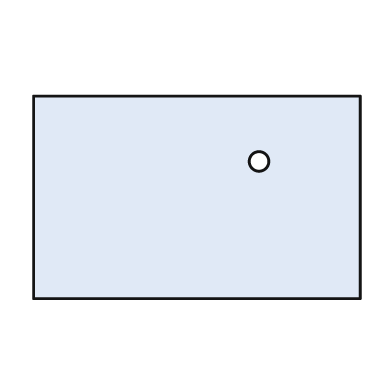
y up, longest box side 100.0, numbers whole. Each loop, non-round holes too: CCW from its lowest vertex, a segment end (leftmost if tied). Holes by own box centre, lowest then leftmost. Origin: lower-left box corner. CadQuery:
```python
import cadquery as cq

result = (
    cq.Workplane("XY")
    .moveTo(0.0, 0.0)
    .lineTo(100.0, 0.0)
    .lineTo(100.0, 62.0)
    .lineTo(0.0, 62.0)
    .close()
    .moveTo(69.0, 42.0)
    .circle(3.0)
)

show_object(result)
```